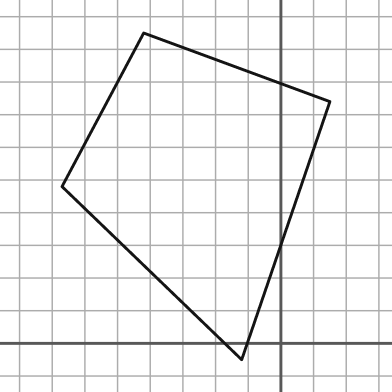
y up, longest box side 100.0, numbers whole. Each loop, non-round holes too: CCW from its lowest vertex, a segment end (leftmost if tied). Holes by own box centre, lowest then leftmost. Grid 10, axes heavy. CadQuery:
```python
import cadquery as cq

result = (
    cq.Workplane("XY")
    .moveTo(-12.0, -5.0)
    .lineTo(15.0, 74.0)
    .lineTo(-42.0, 95.0)
    .lineTo(-67.0, 48.0)
    .close()
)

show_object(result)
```